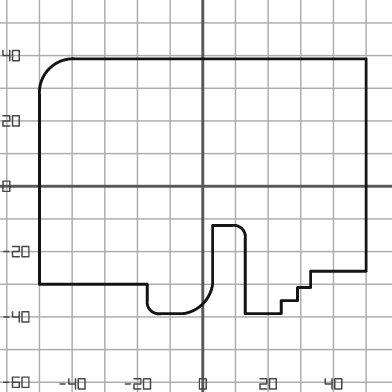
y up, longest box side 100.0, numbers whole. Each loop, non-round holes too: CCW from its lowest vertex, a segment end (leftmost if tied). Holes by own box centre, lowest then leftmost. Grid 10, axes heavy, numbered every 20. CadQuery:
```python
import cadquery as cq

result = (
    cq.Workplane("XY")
    .moveTo(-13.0, -39.0)
    .lineTo(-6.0, -39.0)
    .threePointArc((0.0, -36.0), (3.0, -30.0))
    .lineTo(3.0, -12.0)
    .lineTo(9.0, -12.0)
    .threePointArc((12.0, -13.0), (13.0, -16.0))
    .lineTo(13.0, -39.0)
    .lineTo(24.0, -39.0)
    .lineTo(24.0, -35.0)
    .lineTo(29.0, -35.0)
    .lineTo(29.0, -31.0)
    .lineTo(33.0, -31.0)
    .lineTo(33.0, -26.0)
    .lineTo(50.0, -26.0)
    .lineTo(50.0, 39.0)
    .lineTo(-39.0, 39.0)
    .threePointArc((-47.0, 36.0), (-50.0, 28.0))
    .lineTo(-50.0, -30.0)
    .lineTo(-17.0, -30.0)
    .lineTo(-17.0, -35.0)
    .threePointArc((-16.0, -38.0), (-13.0, -39.0))
    .close()
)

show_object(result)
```